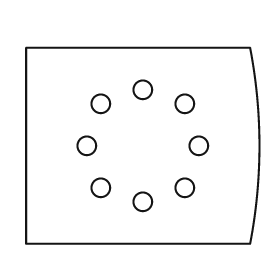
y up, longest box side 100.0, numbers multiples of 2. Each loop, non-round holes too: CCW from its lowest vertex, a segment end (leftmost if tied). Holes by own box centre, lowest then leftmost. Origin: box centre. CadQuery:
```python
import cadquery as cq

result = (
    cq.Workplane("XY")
    .moveTo(-50.0, -42.0)
    .lineTo(46.0, -42.0)
    .threePointArc((50.0, 0.0), (46.0, 42.0))
    .lineTo(-50.0, 42.0)
    .close()
    .moveTo(0.0, -24.0)
    .circle(4.0)
    .moveTo(-18.0, -18.0)
    .circle(4.0)
    .moveTo(18.0, -18.0)
    .circle(4.0)
    .moveTo(-24.0, 0.0)
    .circle(4.0)
    .moveTo(24.0, 0.0)
    .circle(4.0)
    .moveTo(-18.0, 18.0)
    .circle(4.0)
    .moveTo(18.0, 18.0)
    .circle(4.0)
    .moveTo(0.0, 24.0)
    .circle(4.0)
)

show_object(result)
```